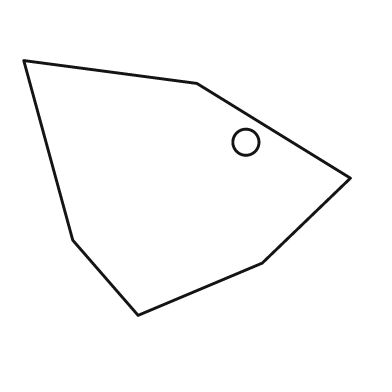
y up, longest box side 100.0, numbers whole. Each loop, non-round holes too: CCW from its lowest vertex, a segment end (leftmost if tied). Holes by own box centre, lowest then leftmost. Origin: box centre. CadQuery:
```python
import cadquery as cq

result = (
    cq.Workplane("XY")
    .moveTo(-15.0, -39.0)
    .lineTo(23.0, -23.0)
    .lineTo(50.0, 3.0)
    .lineTo(3.0, 32.0)
    .lineTo(-50.0, 39.0)
    .lineTo(-35.0, -16.0)
    .close()
    .moveTo(18.0, 14.0)
    .circle(4.0)
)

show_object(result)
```